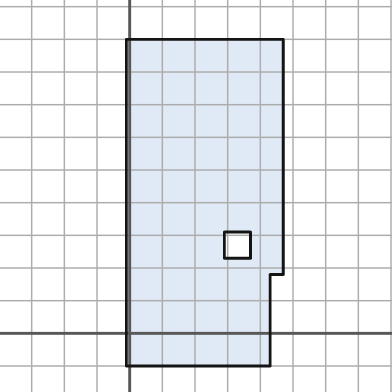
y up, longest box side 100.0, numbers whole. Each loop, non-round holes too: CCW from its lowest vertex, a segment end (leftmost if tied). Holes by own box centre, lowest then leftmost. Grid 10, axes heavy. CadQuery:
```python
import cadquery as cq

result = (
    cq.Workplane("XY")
    .moveTo(-1.0, -10.0)
    .lineTo(43.0, -10.0)
    .lineTo(43.0, 18.0)
    .lineTo(47.0, 18.0)
    .lineTo(47.0, 90.0)
    .lineTo(-1.0, 90.0)
    .close()
    .moveTo(29.0, 23.0)
    .lineTo(37.0, 23.0)
    .lineTo(37.0, 31.0)
    .lineTo(29.0, 31.0)
    .close()
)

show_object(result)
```